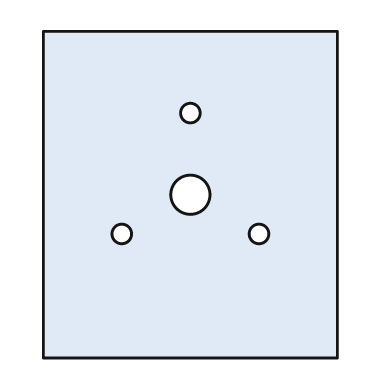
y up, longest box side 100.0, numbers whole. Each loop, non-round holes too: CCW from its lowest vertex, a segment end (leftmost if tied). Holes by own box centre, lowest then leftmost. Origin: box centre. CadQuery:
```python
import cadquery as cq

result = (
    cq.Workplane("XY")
    .moveTo(-45.0, -50.0)
    .lineTo(45.0, -50.0)
    .lineTo(45.0, 50.0)
    .lineTo(-45.0, 50.0)
    .close()
    .moveTo(-21.0, -12.0)
    .circle(3.0)
    .moveTo(21.0, -12.0)
    .circle(3.0)
    .moveTo(0.0, 0.0)
    .circle(6.0)
    .moveTo(0.0, 25.0)
    .circle(3.0)
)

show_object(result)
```